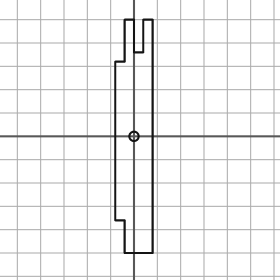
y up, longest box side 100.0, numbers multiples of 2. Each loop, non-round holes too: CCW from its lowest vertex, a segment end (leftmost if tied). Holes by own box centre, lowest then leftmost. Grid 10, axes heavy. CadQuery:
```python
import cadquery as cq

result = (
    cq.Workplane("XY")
    .moveTo(-4.0, -50.0)
    .lineTo(8.0, -50.0)
    .lineTo(8.0, 50.0)
    .lineTo(4.0, 50.0)
    .lineTo(4.0, 36.0)
    .lineTo(0.0, 36.0)
    .lineTo(0.0, 50.0)
    .lineTo(-4.0, 50.0)
    .lineTo(-4.0, 32.0)
    .lineTo(-8.0, 32.0)
    .lineTo(-8.0, -36.0)
    .lineTo(-4.0, -36.0)
    .close()
    .moveTo(0.0, 0.0)
    .circle(2.0)
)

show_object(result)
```